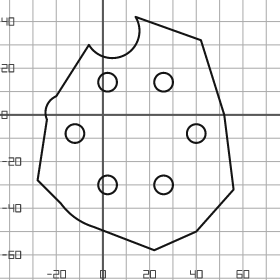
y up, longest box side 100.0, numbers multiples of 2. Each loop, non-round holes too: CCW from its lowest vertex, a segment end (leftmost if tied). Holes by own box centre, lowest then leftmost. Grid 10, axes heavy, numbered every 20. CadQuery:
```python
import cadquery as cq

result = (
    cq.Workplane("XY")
    .moveTo(22.0, -58.0)
    .lineTo(40.0, -50.0)
    .lineTo(56.0, -32.0)
    .lineTo(52.0, 0.0)
    .lineTo(42.0, 32.0)
    .lineTo(14.0, 42.0)
    .threePointArc((10.0, 26.0), (-6.0, 30.0))
    .lineTo(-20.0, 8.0)
    .threePointArc((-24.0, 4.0), (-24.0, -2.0))
    .lineTo(-28.0, -28.0)
    .lineTo(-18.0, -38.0)
    .threePointArc((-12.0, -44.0), (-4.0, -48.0))
    .close()
    .moveTo(2.0, -30.0)
    .circle(4.0)
    .moveTo(26.0, -30.0)
    .circle(4.0)
    .moveTo(-12.0, -8.0)
    .circle(4.0)
    .moveTo(40.0, -8.0)
    .circle(4.0)
    .moveTo(2.0, 14.0)
    .circle(4.0)
    .moveTo(26.0, 14.0)
    .circle(4.0)
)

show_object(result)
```